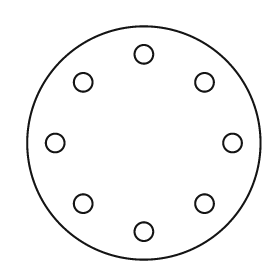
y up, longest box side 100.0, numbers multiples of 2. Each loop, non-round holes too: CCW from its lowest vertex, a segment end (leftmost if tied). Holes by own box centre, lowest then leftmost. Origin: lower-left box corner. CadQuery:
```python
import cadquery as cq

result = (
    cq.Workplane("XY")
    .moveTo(50.0, 50.0)
    .circle(50.0)
    .moveTo(50.0, 12.0)
    .circle(4.0)
    .moveTo(24.0, 24.0)
    .circle(4.0)
    .moveTo(76.0, 24.0)
    .circle(4.0)
    .moveTo(12.0, 50.0)
    .circle(4.0)
    .moveTo(88.0, 50.0)
    .circle(4.0)
    .moveTo(24.0, 76.0)
    .circle(4.0)
    .moveTo(76.0, 76.0)
    .circle(4.0)
    .moveTo(50.0, 88.0)
    .circle(4.0)
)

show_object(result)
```